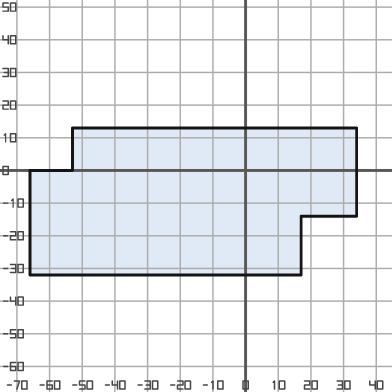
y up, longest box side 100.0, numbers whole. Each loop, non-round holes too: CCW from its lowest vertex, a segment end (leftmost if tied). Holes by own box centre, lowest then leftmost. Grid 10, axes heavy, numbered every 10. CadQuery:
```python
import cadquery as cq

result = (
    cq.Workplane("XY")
    .moveTo(-66.0, -32.0)
    .lineTo(17.0, -32.0)
    .lineTo(17.0, -14.0)
    .lineTo(34.0, -14.0)
    .lineTo(34.0, 13.0)
    .lineTo(-53.0, 13.0)
    .lineTo(-53.0, 0.0)
    .lineTo(-66.0, 0.0)
    .close()
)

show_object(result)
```